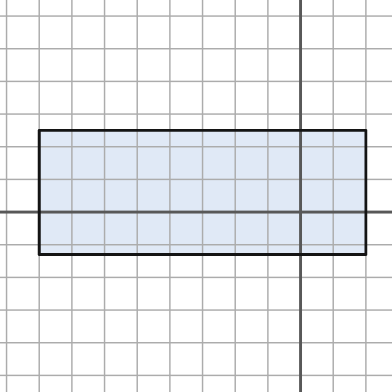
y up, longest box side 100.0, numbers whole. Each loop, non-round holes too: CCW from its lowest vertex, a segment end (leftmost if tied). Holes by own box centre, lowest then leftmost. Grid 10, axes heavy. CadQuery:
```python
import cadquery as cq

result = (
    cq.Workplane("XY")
    .moveTo(-80.0, -13.0)
    .lineTo(20.0, -13.0)
    .lineTo(20.0, 25.0)
    .lineTo(-80.0, 25.0)
    .close()
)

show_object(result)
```